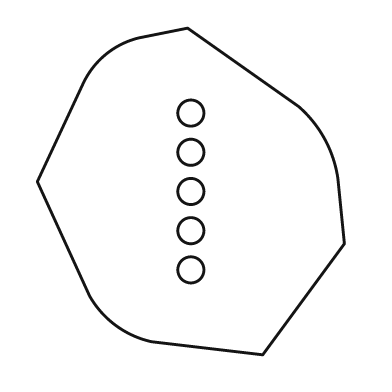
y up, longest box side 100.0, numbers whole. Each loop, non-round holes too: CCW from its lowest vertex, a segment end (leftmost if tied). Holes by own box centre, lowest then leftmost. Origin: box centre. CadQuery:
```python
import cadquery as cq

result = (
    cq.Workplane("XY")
    .moveTo(22.0, -50.0)
    .lineTo(47.0, -16.0)
    .lineTo(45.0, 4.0)
    .threePointArc((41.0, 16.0), (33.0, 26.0))
    .lineTo(-1.0, 50.0)
    .lineTo(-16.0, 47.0)
    .threePointArc((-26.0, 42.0), (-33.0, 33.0))
    .lineTo(-47.0, 3.0)
    .lineTo(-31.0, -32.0)
    .threePointArc((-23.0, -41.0), (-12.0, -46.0))
    .close()
    .moveTo(0.0, -24.0)
    .circle(4.0)
    .moveTo(0.0, -12.0)
    .circle(4.0)
    .moveTo(0.0, 0.0)
    .circle(4.0)
    .moveTo(0.0, 12.0)
    .circle(4.0)
    .moveTo(0.0, 24.0)
    .circle(4.0)
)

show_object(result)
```